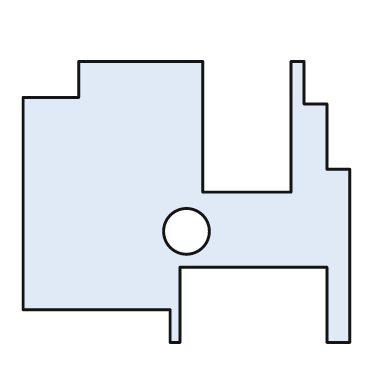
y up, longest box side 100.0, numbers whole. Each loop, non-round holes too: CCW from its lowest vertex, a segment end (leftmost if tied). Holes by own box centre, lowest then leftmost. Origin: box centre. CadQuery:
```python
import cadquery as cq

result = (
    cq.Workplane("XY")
    .moveTo(-5.0, -43.0)
    .lineTo(-2.0, -43.0)
    .lineTo(-2.0, -20.0)
    .lineTo(43.0, -20.0)
    .lineTo(43.0, -43.0)
    .lineTo(50.0, -43.0)
    .lineTo(50.0, 10.0)
    .lineTo(43.0, 10.0)
    .lineTo(43.0, 30.0)
    .lineTo(36.0, 30.0)
    .lineTo(36.0, 43.0)
    .lineTo(32.0, 43.0)
    .lineTo(32.0, 3.0)
    .lineTo(5.0, 3.0)
    .lineTo(5.0, 43.0)
    .lineTo(-33.0, 43.0)
    .lineTo(-33.0, 32.0)
    .lineTo(-50.0, 32.0)
    .lineTo(-50.0, -33.0)
    .lineTo(-5.0, -33.0)
    .close()
    .moveTo(0.0, -9.0)
    .circle(7.0)
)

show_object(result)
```